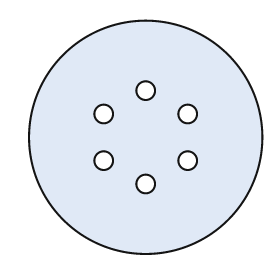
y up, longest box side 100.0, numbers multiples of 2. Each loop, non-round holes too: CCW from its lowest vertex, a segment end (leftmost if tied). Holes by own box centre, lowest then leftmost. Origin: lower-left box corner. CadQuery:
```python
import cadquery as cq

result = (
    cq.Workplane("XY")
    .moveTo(50.0, 50.0)
    .circle(50.0)
    .moveTo(50.0, 30.0)
    .circle(4.0)
    .moveTo(32.0, 40.0)
    .circle(4.0)
    .moveTo(68.0, 40.0)
    .circle(4.0)
    .moveTo(32.0, 60.0)
    .circle(4.0)
    .moveTo(68.0, 60.0)
    .circle(4.0)
    .moveTo(50.0, 70.0)
    .circle(4.0)
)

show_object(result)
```